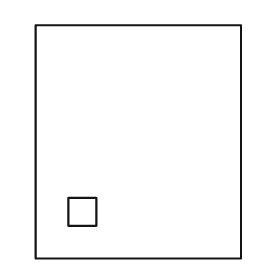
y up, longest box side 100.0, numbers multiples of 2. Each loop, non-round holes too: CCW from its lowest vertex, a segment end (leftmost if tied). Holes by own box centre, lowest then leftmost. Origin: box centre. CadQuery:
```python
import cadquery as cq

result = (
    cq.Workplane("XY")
    .moveTo(-44.0, -50.0)
    .lineTo(44.0, -50.0)
    .lineTo(44.0, 50.0)
    .lineTo(-44.0, 50.0)
    .close()
    .moveTo(-30.0, -36.0)
    .lineTo(-18.0, -36.0)
    .lineTo(-18.0, -24.0)
    .lineTo(-30.0, -24.0)
    .close()
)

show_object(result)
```